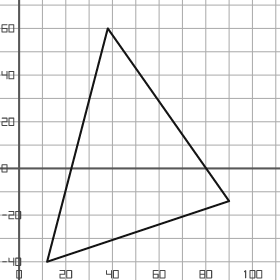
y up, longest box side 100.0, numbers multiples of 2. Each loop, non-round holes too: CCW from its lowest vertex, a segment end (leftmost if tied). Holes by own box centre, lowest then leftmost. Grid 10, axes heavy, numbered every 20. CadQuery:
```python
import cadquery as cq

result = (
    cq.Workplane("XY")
    .moveTo(12.0, -40.0)
    .lineTo(90.0, -14.0)
    .lineTo(38.0, 60.0)
    .close()
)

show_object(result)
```